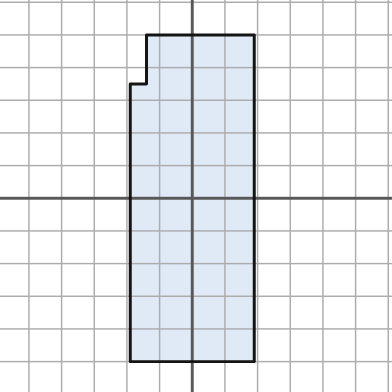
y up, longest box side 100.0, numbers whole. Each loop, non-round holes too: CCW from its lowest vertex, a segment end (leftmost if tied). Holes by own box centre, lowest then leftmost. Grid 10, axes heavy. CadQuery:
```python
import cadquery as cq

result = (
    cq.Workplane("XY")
    .moveTo(-19.0, -50.0)
    .lineTo(19.0, -50.0)
    .lineTo(19.0, 50.0)
    .lineTo(-14.0, 50.0)
    .lineTo(-14.0, 35.0)
    .lineTo(-19.0, 35.0)
    .close()
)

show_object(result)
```